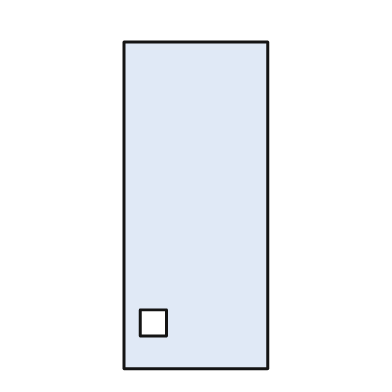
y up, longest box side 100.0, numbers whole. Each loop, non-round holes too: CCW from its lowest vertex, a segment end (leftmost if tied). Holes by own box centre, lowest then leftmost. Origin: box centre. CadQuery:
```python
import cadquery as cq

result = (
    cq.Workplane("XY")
    .moveTo(-22.0, -50.0)
    .lineTo(22.0, -50.0)
    .lineTo(22.0, 50.0)
    .lineTo(-22.0, 50.0)
    .close()
    .moveTo(-17.0, -40.0)
    .lineTo(-9.0, -40.0)
    .lineTo(-9.0, -32.0)
    .lineTo(-17.0, -32.0)
    .close()
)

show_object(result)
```